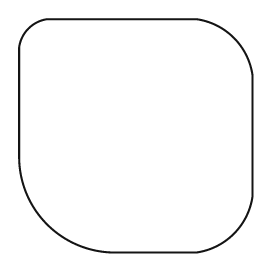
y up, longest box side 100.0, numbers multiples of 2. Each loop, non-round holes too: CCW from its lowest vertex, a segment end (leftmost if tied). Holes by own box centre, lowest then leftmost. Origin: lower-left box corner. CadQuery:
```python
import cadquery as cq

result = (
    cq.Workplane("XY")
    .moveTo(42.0, 0.0)
    .lineTo(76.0, 0.0)
    .threePointArc((92.0, 8.0), (100.0, 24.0))
    .lineTo(100.0, 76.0)
    .threePointArc((92.0, 92.0), (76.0, 100.0))
    .lineTo(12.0, 100.0)
    .threePointArc((4.0, 96.0), (0.0, 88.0))
    .lineTo(0.0, 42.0)
    .threePointArc((12.0, 12.0), (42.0, 0.0))
    .close()
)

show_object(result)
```